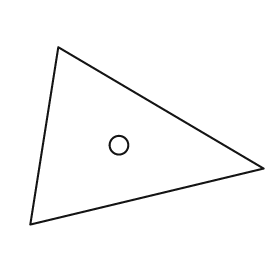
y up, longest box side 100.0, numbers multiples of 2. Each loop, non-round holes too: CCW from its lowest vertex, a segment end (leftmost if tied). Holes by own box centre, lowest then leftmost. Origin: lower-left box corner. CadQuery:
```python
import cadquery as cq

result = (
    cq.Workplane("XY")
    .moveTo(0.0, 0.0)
    .lineTo(100.0, 24.0)
    .lineTo(12.0, 76.0)
    .close()
    .moveTo(38.0, 34.0)
    .circle(4.0)
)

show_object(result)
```